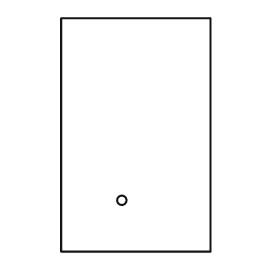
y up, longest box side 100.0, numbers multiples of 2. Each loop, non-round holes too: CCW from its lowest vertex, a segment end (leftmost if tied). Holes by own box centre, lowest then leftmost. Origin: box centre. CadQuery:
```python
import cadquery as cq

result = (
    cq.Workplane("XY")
    .moveTo(-32.0, -50.0)
    .lineTo(32.0, -50.0)
    .lineTo(32.0, 50.0)
    .lineTo(-32.0, 50.0)
    .close()
    .moveTo(-6.0, -28.0)
    .circle(2.0)
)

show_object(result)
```